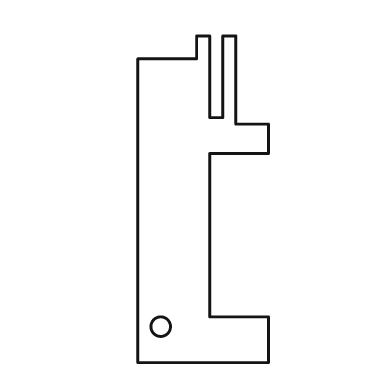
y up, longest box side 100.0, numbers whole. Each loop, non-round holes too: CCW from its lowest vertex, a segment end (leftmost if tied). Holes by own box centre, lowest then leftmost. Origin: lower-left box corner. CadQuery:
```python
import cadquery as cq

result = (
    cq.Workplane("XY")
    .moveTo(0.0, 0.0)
    .lineTo(40.0, 0.0)
    .lineTo(40.0, 14.0)
    .lineTo(22.0, 14.0)
    .lineTo(22.0, 64.0)
    .lineTo(40.0, 64.0)
    .lineTo(40.0, 73.0)
    .lineTo(30.0, 73.0)
    .lineTo(30.0, 100.0)
    .lineTo(26.0, 100.0)
    .lineTo(26.0, 75.0)
    .lineTo(22.0, 75.0)
    .lineTo(22.0, 100.0)
    .lineTo(18.0, 100.0)
    .lineTo(18.0, 93.0)
    .lineTo(0.0, 93.0)
    .close()
    .moveTo(7.0, 11.0)
    .circle(3.0)
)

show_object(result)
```